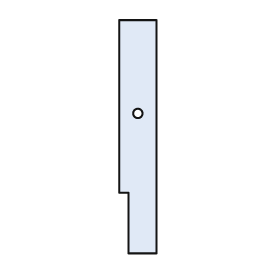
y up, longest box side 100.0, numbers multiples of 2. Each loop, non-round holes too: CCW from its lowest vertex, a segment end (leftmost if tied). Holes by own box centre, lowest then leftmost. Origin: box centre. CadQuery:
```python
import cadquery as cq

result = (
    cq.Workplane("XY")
    .moveTo(-4.0, -50.0)
    .lineTo(8.0, -50.0)
    .lineTo(8.0, 50.0)
    .lineTo(-8.0, 50.0)
    .lineTo(-8.0, -24.0)
    .lineTo(-4.0, -24.0)
    .close()
    .moveTo(0.0, 10.0)
    .circle(2.0)
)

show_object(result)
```